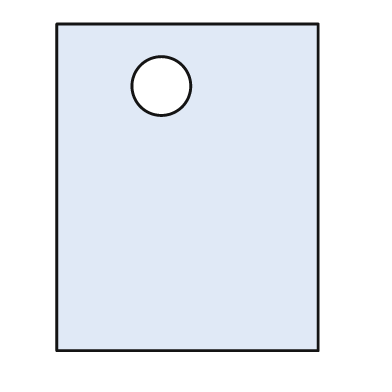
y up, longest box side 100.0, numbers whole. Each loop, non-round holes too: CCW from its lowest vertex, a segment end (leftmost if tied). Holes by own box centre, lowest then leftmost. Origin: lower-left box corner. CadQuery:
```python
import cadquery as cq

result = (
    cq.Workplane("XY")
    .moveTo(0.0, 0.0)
    .lineTo(80.0, 0.0)
    .lineTo(80.0, 100.0)
    .lineTo(0.0, 100.0)
    .close()
    .moveTo(32.0, 81.0)
    .circle(9.0)
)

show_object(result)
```